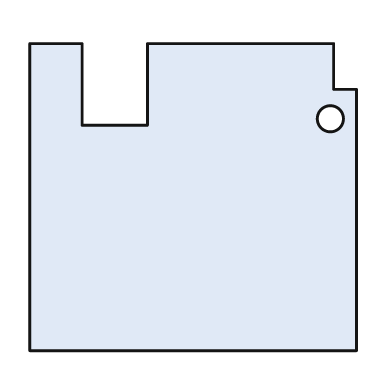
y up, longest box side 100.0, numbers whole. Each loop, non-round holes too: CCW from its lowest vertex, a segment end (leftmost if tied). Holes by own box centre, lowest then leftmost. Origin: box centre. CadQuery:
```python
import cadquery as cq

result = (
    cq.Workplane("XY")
    .moveTo(-50.0, -47.0)
    .lineTo(50.0, -47.0)
    .lineTo(50.0, 33.0)
    .lineTo(43.0, 33.0)
    .lineTo(43.0, 47.0)
    .lineTo(-14.0, 47.0)
    .lineTo(-14.0, 22.0)
    .lineTo(-34.0, 22.0)
    .lineTo(-34.0, 47.0)
    .lineTo(-50.0, 47.0)
    .close()
    .moveTo(42.0, 24.0)
    .circle(4.0)
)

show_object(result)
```